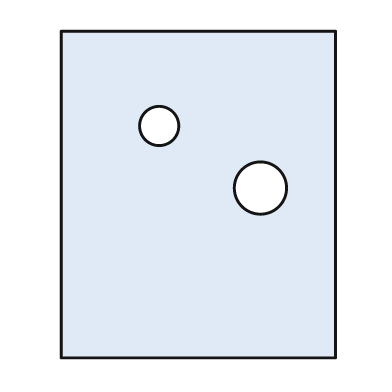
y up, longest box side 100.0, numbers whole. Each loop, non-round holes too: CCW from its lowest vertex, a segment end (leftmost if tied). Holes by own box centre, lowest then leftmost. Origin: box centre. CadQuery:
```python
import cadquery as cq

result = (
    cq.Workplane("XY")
    .moveTo(-42.0, -50.0)
    .lineTo(42.0, -50.0)
    .lineTo(42.0, 50.0)
    .lineTo(-42.0, 50.0)
    .close()
    .moveTo(19.0, 2.0)
    .circle(8.0)
    .moveTo(-12.0, 21.0)
    .circle(6.0)
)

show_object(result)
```